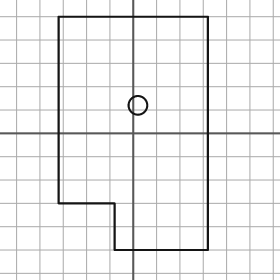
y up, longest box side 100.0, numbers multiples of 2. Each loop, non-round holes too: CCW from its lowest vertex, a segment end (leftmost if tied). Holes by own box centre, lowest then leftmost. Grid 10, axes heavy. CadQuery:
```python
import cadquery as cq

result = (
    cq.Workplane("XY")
    .moveTo(-8.0, -50.0)
    .lineTo(32.0, -50.0)
    .lineTo(32.0, 50.0)
    .lineTo(-32.0, 50.0)
    .lineTo(-32.0, -30.0)
    .lineTo(-8.0, -30.0)
    .close()
    .moveTo(2.0, 12.0)
    .circle(4.0)
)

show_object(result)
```